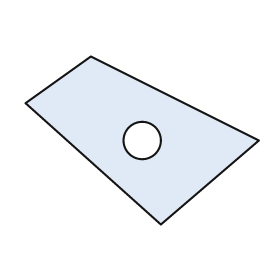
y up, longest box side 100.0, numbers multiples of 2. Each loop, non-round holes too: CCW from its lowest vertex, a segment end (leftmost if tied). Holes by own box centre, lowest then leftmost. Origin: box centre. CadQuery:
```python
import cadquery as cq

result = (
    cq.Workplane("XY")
    .moveTo(8.0, -36.0)
    .lineTo(50.0, 0.0)
    .lineTo(-22.0, 36.0)
    .lineTo(-50.0, 16.0)
    .close()
    .moveTo(0.0, 0.0)
    .circle(8.0)
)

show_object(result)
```